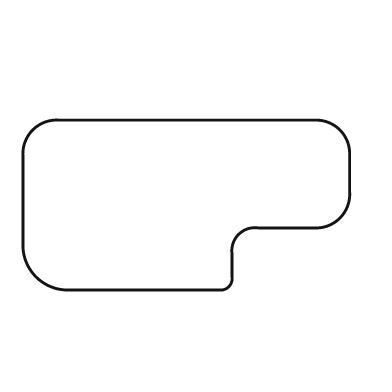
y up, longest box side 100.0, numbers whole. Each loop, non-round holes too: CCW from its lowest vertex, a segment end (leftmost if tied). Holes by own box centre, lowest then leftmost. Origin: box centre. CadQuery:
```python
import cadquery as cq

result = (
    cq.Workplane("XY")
    .moveTo(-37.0, -26.0)
    .lineTo(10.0, -26.0)
    .threePointArc((13.0, -25.0), (14.0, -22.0))
    .lineTo(14.0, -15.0)
    .threePointArc((16.0, -9.0), (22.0, -7.0))
    .lineTo(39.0, -7.0)
    .threePointArc((47.0, -4.0), (50.0, 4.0))
    .lineTo(50.0, 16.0)
    .threePointArc((47.0, 23.0), (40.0, 26.0))
    .lineTo(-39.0, 26.0)
    .threePointArc((-47.0, 23.0), (-50.0, 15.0))
    .lineTo(-50.0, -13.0)
    .threePointArc((-46.0, -22.0), (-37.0, -26.0))
    .close()
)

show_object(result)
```